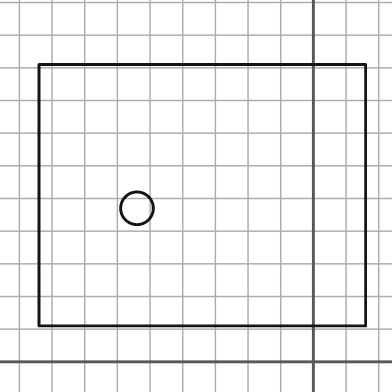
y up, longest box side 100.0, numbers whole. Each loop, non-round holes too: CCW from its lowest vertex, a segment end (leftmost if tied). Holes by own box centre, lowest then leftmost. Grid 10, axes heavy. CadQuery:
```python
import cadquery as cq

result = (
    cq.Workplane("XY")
    .moveTo(-84.0, 11.0)
    .lineTo(16.0, 11.0)
    .lineTo(16.0, 91.0)
    .lineTo(-84.0, 91.0)
    .close()
    .moveTo(-54.0, 47.0)
    .circle(5.0)
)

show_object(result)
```